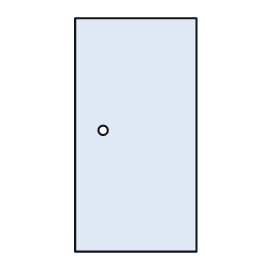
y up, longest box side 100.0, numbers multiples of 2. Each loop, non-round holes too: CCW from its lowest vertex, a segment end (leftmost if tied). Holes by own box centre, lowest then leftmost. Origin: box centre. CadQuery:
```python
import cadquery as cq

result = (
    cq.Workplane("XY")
    .moveTo(-26.0, -50.0)
    .lineTo(26.0, -50.0)
    .lineTo(26.0, 50.0)
    .lineTo(-26.0, 50.0)
    .close()
    .moveTo(-14.0, 2.0)
    .circle(2.0)
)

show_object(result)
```